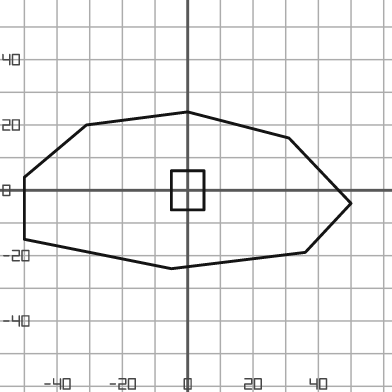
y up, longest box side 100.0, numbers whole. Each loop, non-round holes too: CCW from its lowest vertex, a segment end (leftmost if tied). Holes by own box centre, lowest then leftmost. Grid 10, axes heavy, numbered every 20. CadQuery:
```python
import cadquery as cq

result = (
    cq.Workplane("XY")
    .moveTo(-5.0, -24.0)
    .lineTo(36.0, -19.0)
    .lineTo(50.0, -4.0)
    .lineTo(31.0, 16.0)
    .lineTo(0.0, 24.0)
    .lineTo(-31.0, 20.0)
    .lineTo(-50.0, 4.0)
    .lineTo(-50.0, -15.0)
    .close()
    .moveTo(-5.0, -6.0)
    .lineTo(5.0, -6.0)
    .lineTo(5.0, 6.0)
    .lineTo(-5.0, 6.0)
    .close()
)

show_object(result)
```